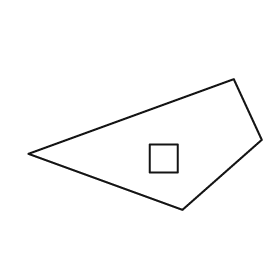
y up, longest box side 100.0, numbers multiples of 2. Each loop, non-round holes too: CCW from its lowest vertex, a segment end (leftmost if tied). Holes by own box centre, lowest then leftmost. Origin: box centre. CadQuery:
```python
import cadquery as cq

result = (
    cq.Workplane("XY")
    .moveTo(16.0, -28.0)
    .lineTo(50.0, 2.0)
    .lineTo(38.0, 28.0)
    .lineTo(-50.0, -4.0)
    .close()
    .moveTo(2.0, -12.0)
    .lineTo(14.0, -12.0)
    .lineTo(14.0, 0.0)
    .lineTo(2.0, 0.0)
    .close()
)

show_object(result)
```